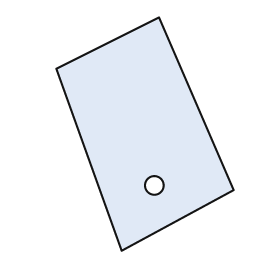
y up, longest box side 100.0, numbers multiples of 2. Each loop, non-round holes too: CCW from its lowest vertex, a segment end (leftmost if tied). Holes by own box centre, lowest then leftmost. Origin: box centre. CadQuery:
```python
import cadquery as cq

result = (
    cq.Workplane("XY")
    .moveTo(-10.0, -50.0)
    .lineTo(38.0, -24.0)
    .lineTo(6.0, 50.0)
    .lineTo(-38.0, 28.0)
    .close()
    .moveTo(4.0, -22.0)
    .circle(4.0)
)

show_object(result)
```